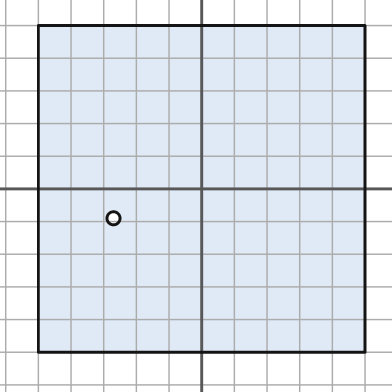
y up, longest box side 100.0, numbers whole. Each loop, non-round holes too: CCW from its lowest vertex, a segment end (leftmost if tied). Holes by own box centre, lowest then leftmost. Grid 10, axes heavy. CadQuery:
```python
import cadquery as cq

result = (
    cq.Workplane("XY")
    .moveTo(-50.0, -50.0)
    .lineTo(50.0, -50.0)
    .lineTo(50.0, 50.0)
    .lineTo(-50.0, 50.0)
    .close()
    .moveTo(-27.0, -9.0)
    .circle(2.0)
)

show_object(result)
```